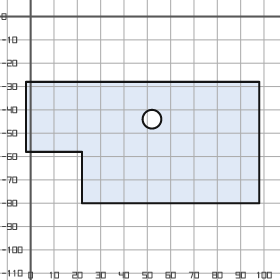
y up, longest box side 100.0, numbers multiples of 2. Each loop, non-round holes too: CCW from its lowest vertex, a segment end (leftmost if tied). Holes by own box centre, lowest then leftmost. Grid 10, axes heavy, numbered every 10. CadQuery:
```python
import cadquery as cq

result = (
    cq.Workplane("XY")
    .moveTo(22.0, -80.0)
    .lineTo(98.0, -80.0)
    .lineTo(98.0, -28.0)
    .lineTo(-2.0, -28.0)
    .lineTo(-2.0, -58.0)
    .lineTo(22.0, -58.0)
    .close()
    .moveTo(52.0, -44.0)
    .circle(4.0)
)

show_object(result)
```